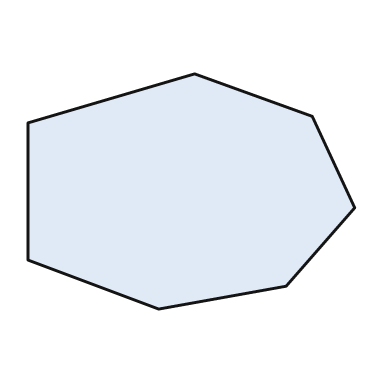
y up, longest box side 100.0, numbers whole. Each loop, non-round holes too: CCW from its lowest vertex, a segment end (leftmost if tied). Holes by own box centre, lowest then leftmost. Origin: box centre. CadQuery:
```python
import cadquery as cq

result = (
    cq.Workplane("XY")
    .moveTo(-10.0, -36.0)
    .lineTo(29.0, -29.0)
    .lineTo(50.0, -5.0)
    .lineTo(37.0, 23.0)
    .lineTo(1.0, 36.0)
    .lineTo(-50.0, 21.0)
    .lineTo(-50.0, -21.0)
    .close()
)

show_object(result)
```